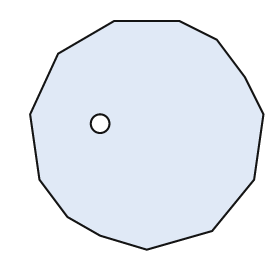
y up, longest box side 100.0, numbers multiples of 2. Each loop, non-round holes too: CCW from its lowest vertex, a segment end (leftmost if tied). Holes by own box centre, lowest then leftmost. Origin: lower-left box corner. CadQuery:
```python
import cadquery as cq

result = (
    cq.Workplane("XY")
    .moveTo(50.0, 0.0)
    .lineTo(78.0, 8.0)
    .lineTo(96.0, 30.0)
    .lineTo(100.0, 58.0)
    .lineTo(92.0, 74.0)
    .lineTo(80.0, 90.0)
    .lineTo(64.0, 98.0)
    .lineTo(36.0, 98.0)
    .lineTo(12.0, 84.0)
    .lineTo(0.0, 58.0)
    .lineTo(4.0, 30.0)
    .lineTo(16.0, 14.0)
    .lineTo(30.0, 6.0)
    .close()
    .moveTo(30.0, 54.0)
    .circle(4.0)
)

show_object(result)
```